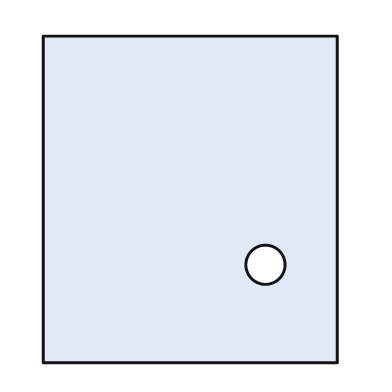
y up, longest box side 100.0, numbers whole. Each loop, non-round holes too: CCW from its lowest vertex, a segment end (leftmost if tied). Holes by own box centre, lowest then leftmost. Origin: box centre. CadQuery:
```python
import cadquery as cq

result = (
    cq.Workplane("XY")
    .moveTo(-45.0, -50.0)
    .lineTo(45.0, -50.0)
    .lineTo(45.0, 50.0)
    .lineTo(-45.0, 50.0)
    .close()
    .moveTo(23.0, -20.0)
    .circle(6.0)
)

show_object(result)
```